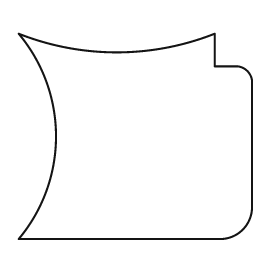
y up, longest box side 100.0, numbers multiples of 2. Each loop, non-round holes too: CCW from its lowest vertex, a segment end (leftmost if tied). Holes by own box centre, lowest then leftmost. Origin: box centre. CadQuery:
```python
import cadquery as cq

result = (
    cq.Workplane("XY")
    .moveTo(-50.0, -44.0)
    .lineTo(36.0, -44.0)
    .threePointArc((46.0, -40.0), (50.0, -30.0))
    .lineTo(50.0, 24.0)
    .threePointArc((48.0, 28.0), (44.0, 30.0))
    .lineTo(34.0, 30.0)
    .lineTo(34.0, 44.0)
    .threePointArc((-8.0, 36.0), (-50.0, 44.0))
    .threePointArc((-34.0, 0.0), (-50.0, -44.0))
    .close()
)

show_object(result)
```